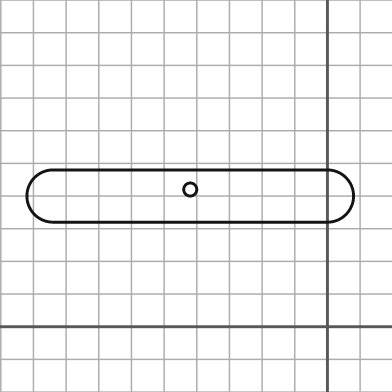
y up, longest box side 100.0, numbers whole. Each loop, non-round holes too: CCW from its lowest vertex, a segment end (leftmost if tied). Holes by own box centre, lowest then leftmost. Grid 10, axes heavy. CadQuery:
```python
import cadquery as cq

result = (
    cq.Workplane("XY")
    .moveTo(-84.0, 32.0)
    .lineTo(0.0, 32.0)
    .threePointArc((8.0, 40.0), (0.0, 48.0))
    .lineTo(-84.0, 48.0)
    .threePointArc((-92.0, 40.0), (-84.0, 32.0))
    .close()
    .moveTo(-42.0, 42.0)
    .circle(2.0)
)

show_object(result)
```